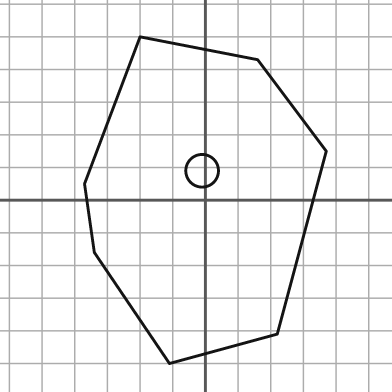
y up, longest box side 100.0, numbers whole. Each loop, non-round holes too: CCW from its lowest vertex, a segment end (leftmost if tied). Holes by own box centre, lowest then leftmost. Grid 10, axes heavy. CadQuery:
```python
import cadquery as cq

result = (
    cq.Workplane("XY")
    .moveTo(-11.0, -50.0)
    .lineTo(22.0, -41.0)
    .lineTo(37.0, 15.0)
    .lineTo(16.0, 43.0)
    .lineTo(-20.0, 50.0)
    .lineTo(-37.0, 5.0)
    .lineTo(-34.0, -16.0)
    .close()
    .moveTo(-1.0, 9.0)
    .circle(5.0)
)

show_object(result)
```